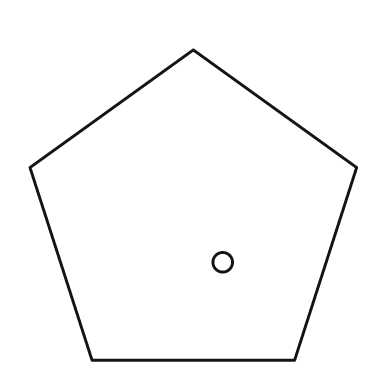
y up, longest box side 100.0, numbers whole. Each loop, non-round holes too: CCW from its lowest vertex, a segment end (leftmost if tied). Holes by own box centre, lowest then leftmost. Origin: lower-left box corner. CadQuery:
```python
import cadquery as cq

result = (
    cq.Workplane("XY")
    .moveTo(19.0, 0.0)
    .lineTo(81.0, 0.0)
    .lineTo(100.0, 59.0)
    .lineTo(50.0, 95.0)
    .lineTo(0.0, 59.0)
    .close()
    .moveTo(59.0, 30.0)
    .circle(3.0)
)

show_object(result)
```